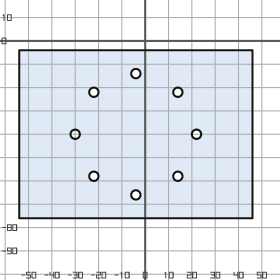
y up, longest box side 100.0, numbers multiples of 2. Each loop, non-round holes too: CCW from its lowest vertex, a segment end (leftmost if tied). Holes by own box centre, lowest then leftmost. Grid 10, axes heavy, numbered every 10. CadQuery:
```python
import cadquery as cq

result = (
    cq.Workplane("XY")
    .moveTo(-54.0, -76.0)
    .lineTo(46.0, -76.0)
    .lineTo(46.0, -4.0)
    .lineTo(-54.0, -4.0)
    .close()
    .moveTo(-4.0, -66.0)
    .circle(2.0)
    .moveTo(-22.0, -58.0)
    .circle(2.0)
    .moveTo(14.0, -58.0)
    .circle(2.0)
    .moveTo(-30.0, -40.0)
    .circle(2.0)
    .moveTo(22.0, -40.0)
    .circle(2.0)
    .moveTo(-22.0, -22.0)
    .circle(2.0)
    .moveTo(14.0, -22.0)
    .circle(2.0)
    .moveTo(-4.0, -14.0)
    .circle(2.0)
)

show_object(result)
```